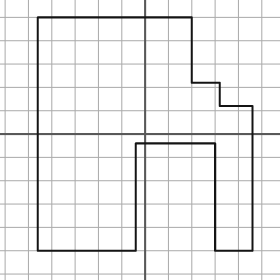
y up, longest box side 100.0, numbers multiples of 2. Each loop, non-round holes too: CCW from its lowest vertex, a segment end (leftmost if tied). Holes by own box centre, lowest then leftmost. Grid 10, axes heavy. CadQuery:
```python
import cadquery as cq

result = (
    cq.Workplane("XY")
    .moveTo(-46.0, -50.0)
    .lineTo(-4.0, -50.0)
    .lineTo(-4.0, -4.0)
    .lineTo(30.0, -4.0)
    .lineTo(30.0, -50.0)
    .lineTo(46.0, -50.0)
    .lineTo(46.0, 12.0)
    .lineTo(32.0, 12.0)
    .lineTo(32.0, 22.0)
    .lineTo(20.0, 22.0)
    .lineTo(20.0, 50.0)
    .lineTo(-46.0, 50.0)
    .close()
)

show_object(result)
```